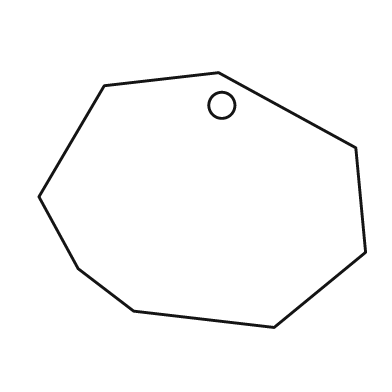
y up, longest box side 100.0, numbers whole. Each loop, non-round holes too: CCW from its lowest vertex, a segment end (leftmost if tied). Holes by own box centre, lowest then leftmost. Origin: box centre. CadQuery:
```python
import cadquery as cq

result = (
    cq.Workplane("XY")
    .moveTo(22.0, -39.0)
    .lineTo(50.0, -16.0)
    .lineTo(47.0, 16.0)
    .lineTo(5.0, 39.0)
    .lineTo(-30.0, 35.0)
    .lineTo(-50.0, 1.0)
    .lineTo(-38.0, -21.0)
    .lineTo(-21.0, -34.0)
    .close()
    .moveTo(6.0, 29.0)
    .circle(4.0)
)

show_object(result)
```